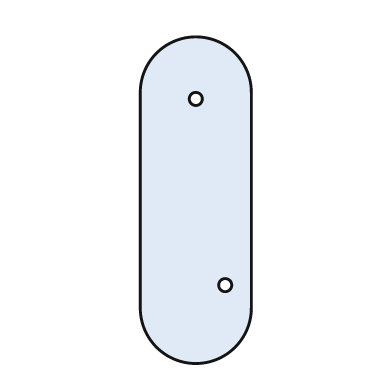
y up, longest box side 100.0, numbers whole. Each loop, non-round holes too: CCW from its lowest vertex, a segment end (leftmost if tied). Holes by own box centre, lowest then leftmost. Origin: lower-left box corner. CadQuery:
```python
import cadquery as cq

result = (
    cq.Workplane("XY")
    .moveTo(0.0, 17.0)
    .threePointArc((17.0, 0.0), (34.0, 17.0))
    .lineTo(34.0, 83.0)
    .threePointArc((17.0, 100.0), (0.0, 83.0))
    .close()
    .moveTo(26.0, 24.0)
    .circle(2.0)
    .moveTo(17.0, 81.0)
    .circle(2.0)
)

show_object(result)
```